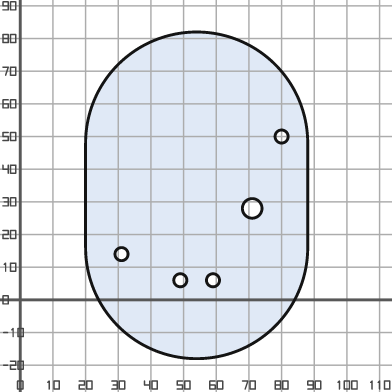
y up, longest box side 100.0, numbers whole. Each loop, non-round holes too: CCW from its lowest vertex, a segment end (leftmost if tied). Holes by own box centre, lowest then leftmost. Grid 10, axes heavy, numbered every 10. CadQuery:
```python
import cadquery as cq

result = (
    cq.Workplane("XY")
    .moveTo(20.0, 16.0)
    .threePointArc((54.0, -18.0), (88.0, 16.0))
    .lineTo(88.0, 48.0)
    .threePointArc((54.0, 82.0), (20.0, 48.0))
    .close()
    .moveTo(49.0, 6.0)
    .circle(2.0)
    .moveTo(59.0, 6.0)
    .circle(2.0)
    .moveTo(31.0, 14.0)
    .circle(2.0)
    .moveTo(71.0, 28.0)
    .circle(3.0)
    .moveTo(80.0, 50.0)
    .circle(2.0)
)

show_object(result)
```